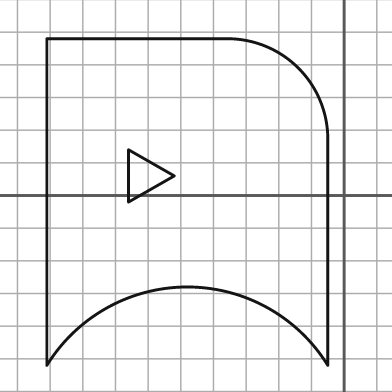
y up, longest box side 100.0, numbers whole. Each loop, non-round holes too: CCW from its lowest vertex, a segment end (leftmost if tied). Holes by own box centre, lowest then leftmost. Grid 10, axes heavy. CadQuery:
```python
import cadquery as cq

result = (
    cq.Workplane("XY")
    .moveTo(-91.0, -52.0)
    .threePointArc((-48.0, -28.0), (-5.0, -52.0))
    .lineTo(-5.0, 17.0)
    .threePointArc((-14.0, 39.0), (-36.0, 48.0))
    .lineTo(-91.0, 48.0)
    .close()
    .moveTo(-66.0, -2.0)
    .lineTo(-52.0, 6.0)
    .lineTo(-66.0, 14.0)
    .close()
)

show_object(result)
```